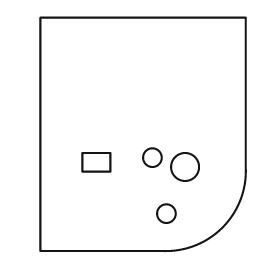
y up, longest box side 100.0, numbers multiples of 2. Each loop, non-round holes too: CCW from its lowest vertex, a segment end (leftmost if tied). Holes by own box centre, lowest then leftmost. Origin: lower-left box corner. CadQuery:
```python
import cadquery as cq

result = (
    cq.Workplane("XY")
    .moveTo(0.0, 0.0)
    .lineTo(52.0, 0.0)
    .threePointArc((78.0, 10.0), (88.0, 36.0))
    .lineTo(88.0, 100.0)
    .lineTo(0.0, 100.0)
    .close()
    .moveTo(54.0, 16.0)
    .circle(4.0)
    .moveTo(62.0, 36.0)
    .circle(6.0)
    .moveTo(18.0, 34.0)
    .lineTo(30.0, 34.0)
    .lineTo(30.0, 42.0)
    .lineTo(18.0, 42.0)
    .close()
    .moveTo(48.0, 40.0)
    .circle(4.0)
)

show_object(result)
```